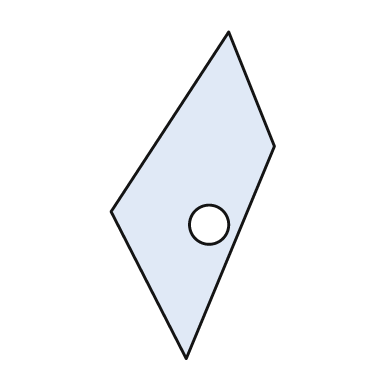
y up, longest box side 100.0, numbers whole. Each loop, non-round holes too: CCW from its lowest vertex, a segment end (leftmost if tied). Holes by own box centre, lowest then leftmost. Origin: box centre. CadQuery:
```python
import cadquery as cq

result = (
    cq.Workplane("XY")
    .moveTo(-2.0, -50.0)
    .lineTo(25.0, 15.0)
    .lineTo(11.0, 50.0)
    .lineTo(-25.0, -5.0)
    .close()
    .moveTo(5.0, -9.0)
    .circle(6.0)
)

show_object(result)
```